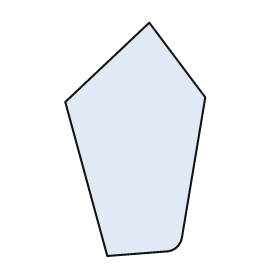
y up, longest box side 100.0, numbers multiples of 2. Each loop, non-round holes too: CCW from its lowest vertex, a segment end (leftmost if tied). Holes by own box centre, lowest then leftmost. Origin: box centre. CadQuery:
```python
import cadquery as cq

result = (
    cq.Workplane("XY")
    .moveTo(-12.0, -50.0)
    .lineTo(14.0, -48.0)
    .threePointArc((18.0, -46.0), (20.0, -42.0))
    .lineTo(30.0, 18.0)
    .lineTo(6.0, 50.0)
    .lineTo(-30.0, 16.0)
    .close()
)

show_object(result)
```